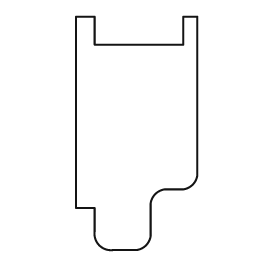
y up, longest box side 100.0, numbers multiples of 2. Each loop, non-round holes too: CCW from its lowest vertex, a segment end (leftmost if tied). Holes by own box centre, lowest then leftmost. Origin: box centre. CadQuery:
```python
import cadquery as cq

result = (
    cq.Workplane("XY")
    .moveTo(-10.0, -50.0)
    .lineTo(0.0, -50.0)
    .threePointArc((4.0, -48.0), (6.0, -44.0))
    .lineTo(6.0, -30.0)
    .threePointArc((8.0, -26.0), (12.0, -24.0))
    .lineTo(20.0, -24.0)
    .threePointArc((24.0, -22.0), (26.0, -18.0))
    .lineTo(26.0, 50.0)
    .lineTo(20.0, 50.0)
    .lineTo(20.0, 38.0)
    .lineTo(-18.0, 38.0)
    .lineTo(-18.0, 50.0)
    .lineTo(-26.0, 50.0)
    .lineTo(-26.0, -32.0)
    .lineTo(-18.0, -32.0)
    .lineTo(-18.0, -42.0)
    .threePointArc((-16.0, -48.0), (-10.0, -50.0))
    .close()
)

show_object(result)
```